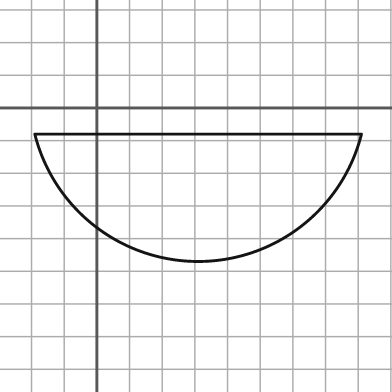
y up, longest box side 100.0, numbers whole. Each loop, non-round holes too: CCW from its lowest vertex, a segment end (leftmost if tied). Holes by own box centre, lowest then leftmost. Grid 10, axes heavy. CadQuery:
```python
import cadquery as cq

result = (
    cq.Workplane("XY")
    .moveTo(-19.0, -8.0)
    .threePointArc((31.0, -47.0), (81.0, -8.0))
    .close()
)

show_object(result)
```